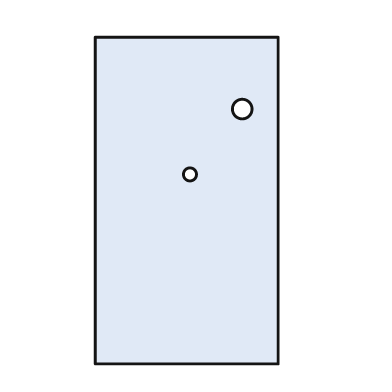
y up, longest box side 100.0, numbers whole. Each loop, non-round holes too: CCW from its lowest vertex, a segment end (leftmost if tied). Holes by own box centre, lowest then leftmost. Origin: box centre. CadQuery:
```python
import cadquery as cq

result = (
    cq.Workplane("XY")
    .moveTo(-28.0, -50.0)
    .lineTo(28.0, -50.0)
    .lineTo(28.0, 50.0)
    .lineTo(-28.0, 50.0)
    .close()
    .moveTo(1.0, 8.0)
    .circle(2.0)
    .moveTo(17.0, 28.0)
    .circle(3.0)
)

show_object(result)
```